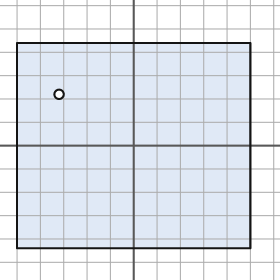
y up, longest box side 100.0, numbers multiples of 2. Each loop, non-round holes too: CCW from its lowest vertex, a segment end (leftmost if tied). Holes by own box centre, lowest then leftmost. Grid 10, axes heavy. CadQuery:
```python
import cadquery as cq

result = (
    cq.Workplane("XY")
    .moveTo(-50.0, -44.0)
    .lineTo(50.0, -44.0)
    .lineTo(50.0, 44.0)
    .lineTo(-50.0, 44.0)
    .close()
    .moveTo(-32.0, 22.0)
    .circle(2.0)
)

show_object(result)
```